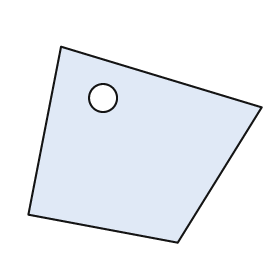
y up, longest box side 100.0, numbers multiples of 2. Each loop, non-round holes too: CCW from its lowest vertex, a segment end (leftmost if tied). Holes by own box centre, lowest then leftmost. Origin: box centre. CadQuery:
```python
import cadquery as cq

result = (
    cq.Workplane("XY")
    .moveTo(14.0, -42.0)
    .lineTo(50.0, 16.0)
    .lineTo(-36.0, 42.0)
    .lineTo(-50.0, -30.0)
    .close()
    .moveTo(-18.0, 20.0)
    .circle(6.0)
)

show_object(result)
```